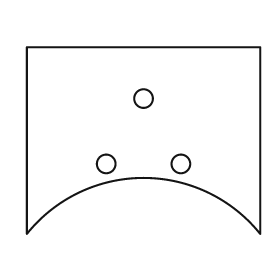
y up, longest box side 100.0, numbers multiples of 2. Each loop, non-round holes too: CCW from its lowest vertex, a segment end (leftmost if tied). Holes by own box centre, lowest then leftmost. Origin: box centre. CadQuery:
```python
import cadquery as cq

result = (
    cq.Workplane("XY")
    .moveTo(-50.0, -40.0)
    .threePointArc((0.0, -16.0), (50.0, -40.0))
    .lineTo(50.0, 40.0)
    .lineTo(-50.0, 40.0)
    .close()
    .moveTo(-16.0, -10.0)
    .circle(4.0)
    .moveTo(16.0, -10.0)
    .circle(4.0)
    .moveTo(0.0, 18.0)
    .circle(4.0)
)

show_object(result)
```